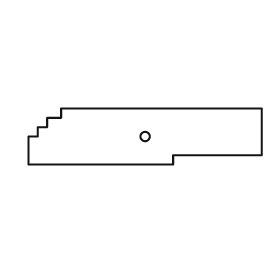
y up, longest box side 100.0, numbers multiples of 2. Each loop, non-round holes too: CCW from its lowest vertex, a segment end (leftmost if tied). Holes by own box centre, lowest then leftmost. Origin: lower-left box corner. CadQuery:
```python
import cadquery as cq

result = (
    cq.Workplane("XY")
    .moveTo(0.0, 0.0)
    .lineTo(62.0, 0.0)
    .lineTo(62.0, 4.0)
    .lineTo(100.0, 4.0)
    .lineTo(100.0, 24.0)
    .lineTo(14.0, 24.0)
    .lineTo(14.0, 20.0)
    .lineTo(8.0, 20.0)
    .lineTo(8.0, 16.0)
    .lineTo(4.0, 16.0)
    .lineTo(4.0, 12.0)
    .lineTo(0.0, 12.0)
    .close()
    .moveTo(50.0, 12.0)
    .circle(2.0)
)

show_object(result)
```